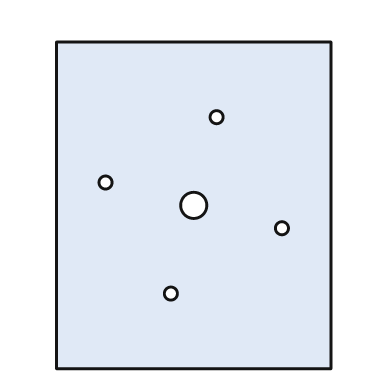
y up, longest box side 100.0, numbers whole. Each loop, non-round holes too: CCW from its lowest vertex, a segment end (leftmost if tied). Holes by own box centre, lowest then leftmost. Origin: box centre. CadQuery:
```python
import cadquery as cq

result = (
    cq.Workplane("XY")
    .moveTo(-42.0, -50.0)
    .lineTo(42.0, -50.0)
    .lineTo(42.0, 50.0)
    .lineTo(-42.0, 50.0)
    .close()
    .moveTo(-7.0, -27.0)
    .circle(2.0)
    .moveTo(27.0, -7.0)
    .circle(2.0)
    .moveTo(0.0, 0.0)
    .circle(4.0)
    .moveTo(-27.0, 7.0)
    .circle(2.0)
    .moveTo(7.0, 27.0)
    .circle(2.0)
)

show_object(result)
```